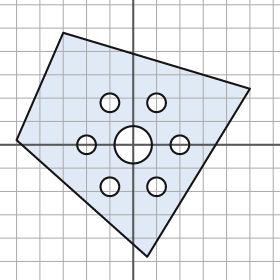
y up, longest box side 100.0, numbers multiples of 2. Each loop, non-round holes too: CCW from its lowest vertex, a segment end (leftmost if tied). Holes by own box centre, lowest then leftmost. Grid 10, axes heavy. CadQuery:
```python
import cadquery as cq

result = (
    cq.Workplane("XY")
    .moveTo(6.0, -48.0)
    .lineTo(50.0, 24.0)
    .lineTo(-30.0, 48.0)
    .lineTo(-50.0, 2.0)
    .close()
    .moveTo(-10.0, -18.0)
    .circle(4.0)
    .moveTo(10.0, -18.0)
    .circle(4.0)
    .moveTo(-20.0, 0.0)
    .circle(4.0)
    .moveTo(0.0, 0.0)
    .circle(8.0)
    .moveTo(20.0, 0.0)
    .circle(4.0)
    .moveTo(-10.0, 18.0)
    .circle(4.0)
    .moveTo(10.0, 18.0)
    .circle(4.0)
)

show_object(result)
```